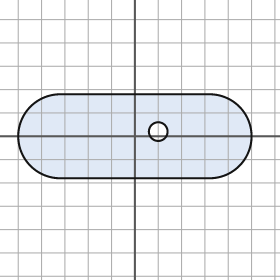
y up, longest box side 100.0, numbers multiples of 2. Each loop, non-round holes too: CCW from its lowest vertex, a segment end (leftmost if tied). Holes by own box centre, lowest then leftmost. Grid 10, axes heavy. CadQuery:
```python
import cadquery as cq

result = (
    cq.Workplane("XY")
    .moveTo(-32.0, -18.0)
    .lineTo(32.0, -18.0)
    .threePointArc((50.0, 0.0), (32.0, 18.0))
    .lineTo(-32.0, 18.0)
    .threePointArc((-50.0, 0.0), (-32.0, -18.0))
    .close()
    .moveTo(10.0, 2.0)
    .circle(4.0)
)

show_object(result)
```